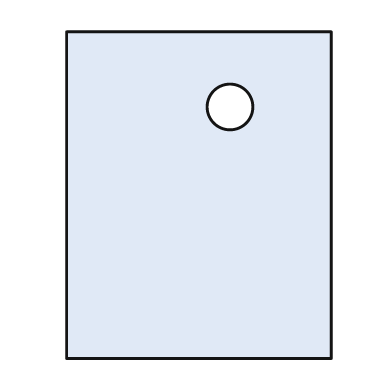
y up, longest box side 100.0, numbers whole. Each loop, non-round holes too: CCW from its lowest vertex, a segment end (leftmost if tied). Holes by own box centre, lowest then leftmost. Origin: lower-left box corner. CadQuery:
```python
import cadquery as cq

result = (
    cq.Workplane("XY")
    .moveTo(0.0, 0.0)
    .lineTo(81.0, 0.0)
    .lineTo(81.0, 100.0)
    .lineTo(0.0, 100.0)
    .close()
    .moveTo(50.0, 77.0)
    .circle(7.0)
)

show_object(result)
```